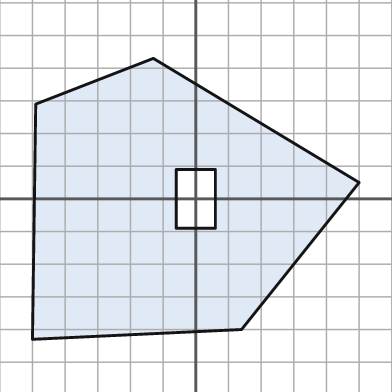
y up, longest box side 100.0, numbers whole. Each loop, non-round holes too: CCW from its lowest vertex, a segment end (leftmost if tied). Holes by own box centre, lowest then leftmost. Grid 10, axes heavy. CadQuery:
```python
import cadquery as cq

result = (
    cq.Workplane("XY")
    .moveTo(-50.0, -43.0)
    .lineTo(14.0, -40.0)
    .lineTo(50.0, 5.0)
    .lineTo(-13.0, 43.0)
    .lineTo(-49.0, 29.0)
    .close()
    .moveTo(-6.0, -9.0)
    .lineTo(6.0, -9.0)
    .lineTo(6.0, 9.0)
    .lineTo(-6.0, 9.0)
    .close()
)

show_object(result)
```